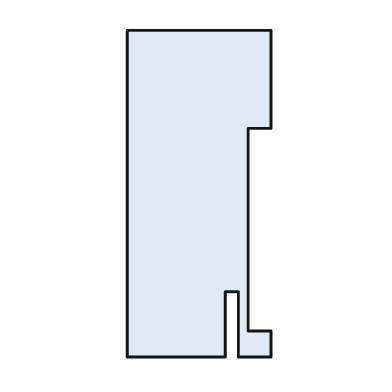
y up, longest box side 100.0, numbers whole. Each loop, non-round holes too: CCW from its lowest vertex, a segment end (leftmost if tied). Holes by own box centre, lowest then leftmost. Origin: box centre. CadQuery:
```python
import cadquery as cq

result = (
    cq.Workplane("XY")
    .moveTo(-22.0, -50.0)
    .lineTo(8.0, -50.0)
    .lineTo(8.0, -30.0)
    .lineTo(12.0, -30.0)
    .lineTo(12.0, -50.0)
    .lineTo(22.0, -50.0)
    .lineTo(22.0, -42.0)
    .lineTo(15.0, -42.0)
    .lineTo(15.0, 20.0)
    .lineTo(22.0, 20.0)
    .lineTo(22.0, 50.0)
    .lineTo(-22.0, 50.0)
    .close()
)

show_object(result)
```